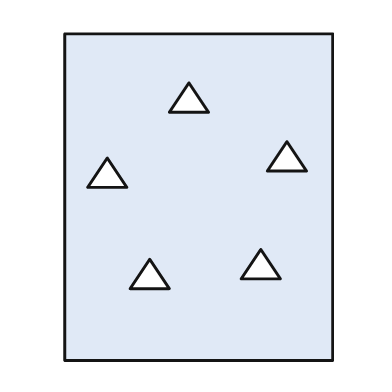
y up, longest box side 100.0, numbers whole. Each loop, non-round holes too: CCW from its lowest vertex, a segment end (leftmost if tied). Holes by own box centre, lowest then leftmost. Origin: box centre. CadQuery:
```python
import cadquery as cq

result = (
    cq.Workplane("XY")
    .moveTo(-41.0, -50.0)
    .lineTo(41.0, -50.0)
    .lineTo(41.0, 50.0)
    .lineTo(-41.0, 50.0)
    .close()
    .moveTo(-21.0, -28.0)
    .lineTo(-9.0, -28.0)
    .lineTo(-15.0, -19.0)
    .close()
    .moveTo(13.0, -25.0)
    .lineTo(25.0, -25.0)
    .lineTo(19.0, -16.0)
    .close()
    .moveTo(-34.0, 3.0)
    .lineTo(-22.0, 3.0)
    .lineTo(-28.0, 12.0)
    .close()
    .moveTo(21.0, 8.0)
    .lineTo(33.0, 8.0)
    .lineTo(27.0, 17.0)
    .close()
    .moveTo(-9.0, 26.0)
    .lineTo(3.0, 26.0)
    .lineTo(-3.0, 35.0)
    .close()
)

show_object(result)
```